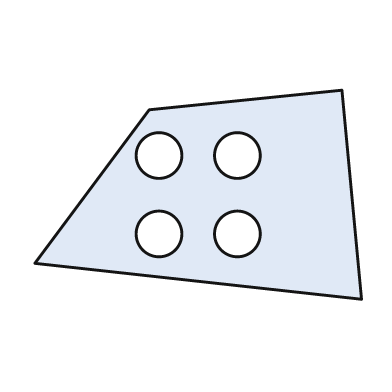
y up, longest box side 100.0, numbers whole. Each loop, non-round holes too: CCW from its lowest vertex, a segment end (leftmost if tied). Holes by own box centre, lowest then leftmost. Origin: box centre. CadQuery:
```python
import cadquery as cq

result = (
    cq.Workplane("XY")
    .moveTo(50.0, -32.0)
    .lineTo(44.0, 32.0)
    .lineTo(-15.0, 26.0)
    .lineTo(-50.0, -21.0)
    .close()
    .moveTo(-12.0, -12.0)
    .circle(7.0)
    .moveTo(12.0, -12.0)
    .circle(7.0)
    .moveTo(-12.0, 12.0)
    .circle(7.0)
    .moveTo(12.0, 12.0)
    .circle(7.0)
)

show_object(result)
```